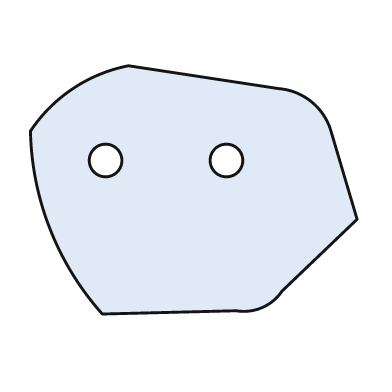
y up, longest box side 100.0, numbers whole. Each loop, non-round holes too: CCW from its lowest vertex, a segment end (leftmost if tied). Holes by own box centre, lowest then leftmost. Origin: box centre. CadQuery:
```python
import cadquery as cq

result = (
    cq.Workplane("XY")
    .moveTo(-28.0, -38.0)
    .lineTo(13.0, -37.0)
    .threePointArc((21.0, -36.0), (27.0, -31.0))
    .lineTo(50.0, -9.0)
    .lineTo(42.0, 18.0)
    .threePointArc((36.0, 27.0), (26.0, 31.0))
    .lineTo(-20.0, 38.0)
    .threePointArc((-37.0, 31.0), (-50.0, 18.0))
    .threePointArc((-44.0, -12.0), (-28.0, -38.0))
    .close()
    .moveTo(-27.0, 9.0)
    .circle(5.0)
    .moveTo(10.0, 9.0)
    .circle(5.0)
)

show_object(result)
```